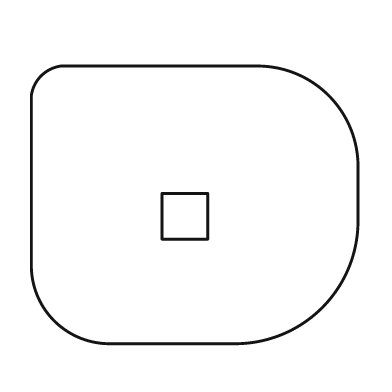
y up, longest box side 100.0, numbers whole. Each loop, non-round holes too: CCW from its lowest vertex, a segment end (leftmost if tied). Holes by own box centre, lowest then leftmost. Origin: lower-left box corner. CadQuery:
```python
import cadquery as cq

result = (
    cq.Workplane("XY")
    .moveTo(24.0, 0.0)
    .lineTo(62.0, 0.0)
    .threePointArc((89.0, 11.0), (100.0, 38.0))
    .lineTo(100.0, 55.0)
    .threePointArc((91.0, 76.0), (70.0, 85.0))
    .lineTo(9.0, 85.0)
    .threePointArc((3.0, 82.0), (0.0, 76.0))
    .lineTo(0.0, 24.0)
    .threePointArc((7.0, 7.0), (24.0, 0.0))
    .close()
    .moveTo(40.0, 32.0)
    .lineTo(54.0, 32.0)
    .lineTo(54.0, 46.0)
    .lineTo(40.0, 46.0)
    .close()
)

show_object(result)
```